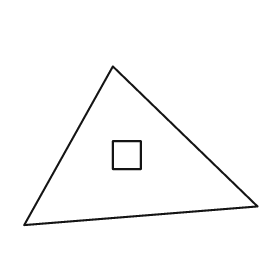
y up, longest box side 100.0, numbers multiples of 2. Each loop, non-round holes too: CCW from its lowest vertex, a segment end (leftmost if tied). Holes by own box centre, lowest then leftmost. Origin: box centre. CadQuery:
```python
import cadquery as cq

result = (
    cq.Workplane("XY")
    .moveTo(-50.0, -34.0)
    .lineTo(50.0, -26.0)
    .lineTo(-12.0, 34.0)
    .close()
    .moveTo(-12.0, -10.0)
    .lineTo(0.0, -10.0)
    .lineTo(0.0, 2.0)
    .lineTo(-12.0, 2.0)
    .close()
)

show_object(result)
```